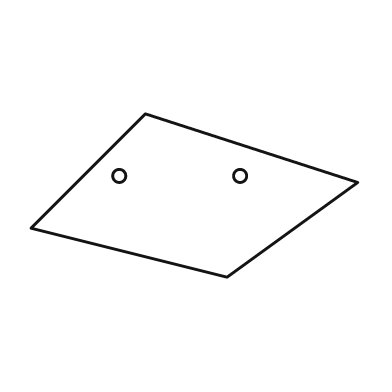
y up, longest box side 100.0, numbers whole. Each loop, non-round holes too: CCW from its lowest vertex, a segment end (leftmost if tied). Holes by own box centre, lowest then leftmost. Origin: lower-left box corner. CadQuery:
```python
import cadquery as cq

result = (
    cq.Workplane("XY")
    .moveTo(60.0, 0.0)
    .lineTo(100.0, 29.0)
    .lineTo(35.0, 50.0)
    .lineTo(0.0, 15.0)
    .close()
    .moveTo(27.0, 31.0)
    .circle(2.0)
    .moveTo(64.0, 31.0)
    .circle(2.0)
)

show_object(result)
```